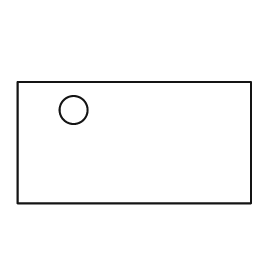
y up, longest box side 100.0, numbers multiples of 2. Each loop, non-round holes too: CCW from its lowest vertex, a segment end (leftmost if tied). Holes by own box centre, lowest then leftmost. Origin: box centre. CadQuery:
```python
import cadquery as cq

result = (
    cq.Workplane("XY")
    .moveTo(-50.0, -26.0)
    .lineTo(50.0, -26.0)
    .lineTo(50.0, 26.0)
    .lineTo(-50.0, 26.0)
    .close()
    .moveTo(-26.0, 14.0)
    .circle(6.0)
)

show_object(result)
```